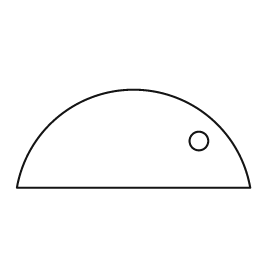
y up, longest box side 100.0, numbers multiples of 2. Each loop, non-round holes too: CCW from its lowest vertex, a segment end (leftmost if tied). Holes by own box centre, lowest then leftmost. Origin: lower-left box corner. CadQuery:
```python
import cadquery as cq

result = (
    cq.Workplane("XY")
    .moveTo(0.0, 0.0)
    .lineTo(100.0, 0.0)
    .threePointArc((50.0, 42.0), (0.0, 0.0))
    .close()
    .moveTo(78.0, 20.0)
    .circle(4.0)
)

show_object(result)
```